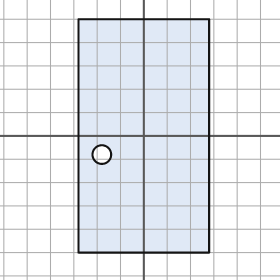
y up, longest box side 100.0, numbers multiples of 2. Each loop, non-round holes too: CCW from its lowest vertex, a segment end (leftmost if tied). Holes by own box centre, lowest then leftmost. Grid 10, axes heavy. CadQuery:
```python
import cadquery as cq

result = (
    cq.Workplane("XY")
    .moveTo(-28.0, -50.0)
    .lineTo(28.0, -50.0)
    .lineTo(28.0, 50.0)
    .lineTo(-28.0, 50.0)
    .close()
    .moveTo(-18.0, -8.0)
    .circle(4.0)
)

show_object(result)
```